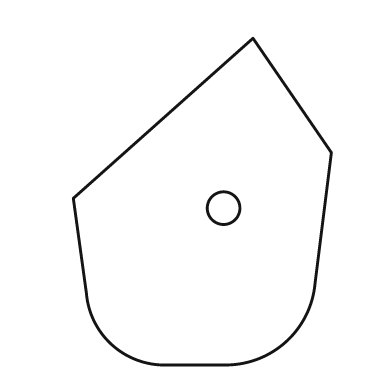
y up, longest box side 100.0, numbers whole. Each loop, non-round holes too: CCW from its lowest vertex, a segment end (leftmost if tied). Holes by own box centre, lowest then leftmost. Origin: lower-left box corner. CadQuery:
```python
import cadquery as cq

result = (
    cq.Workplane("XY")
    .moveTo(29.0, 0.0)
    .lineTo(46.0, 0.0)
    .threePointArc((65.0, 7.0), (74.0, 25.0))
    .lineTo(79.0, 65.0)
    .lineTo(55.0, 100.0)
    .lineTo(0.0, 51.0)
    .lineTo(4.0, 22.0)
    .threePointArc((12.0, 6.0), (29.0, 0.0))
    .close()
    .moveTo(46.0, 48.0)
    .circle(5.0)
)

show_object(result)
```